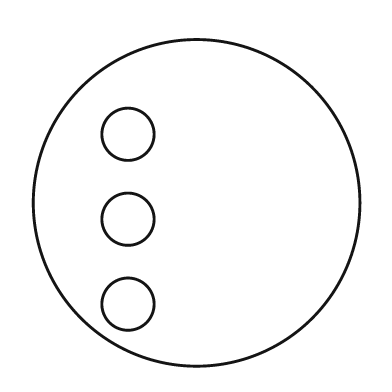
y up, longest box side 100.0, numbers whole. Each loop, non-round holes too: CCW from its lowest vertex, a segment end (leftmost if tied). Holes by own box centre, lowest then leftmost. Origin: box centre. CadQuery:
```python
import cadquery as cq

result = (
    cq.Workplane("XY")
    .moveTo(0.0, 0.0)
    .circle(50.0)
    .moveTo(-21.0, -31.0)
    .circle(8.0)
    .moveTo(-21.0, -5.0)
    .circle(8.0)
    .moveTo(-21.0, 21.0)
    .circle(8.0)
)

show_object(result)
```